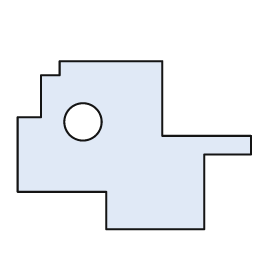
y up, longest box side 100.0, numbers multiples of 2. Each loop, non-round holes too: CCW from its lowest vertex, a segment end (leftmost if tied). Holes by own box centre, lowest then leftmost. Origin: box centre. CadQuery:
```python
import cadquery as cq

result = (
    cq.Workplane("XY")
    .moveTo(-12.0, -36.0)
    .lineTo(30.0, -36.0)
    .lineTo(30.0, -4.0)
    .lineTo(50.0, -4.0)
    .lineTo(50.0, 4.0)
    .lineTo(12.0, 4.0)
    .lineTo(12.0, 36.0)
    .lineTo(-32.0, 36.0)
    .lineTo(-32.0, 30.0)
    .lineTo(-40.0, 30.0)
    .lineTo(-40.0, 12.0)
    .lineTo(-50.0, 12.0)
    .lineTo(-50.0, -20.0)
    .lineTo(-12.0, -20.0)
    .close()
    .moveTo(-22.0, 10.0)
    .circle(8.0)
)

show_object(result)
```